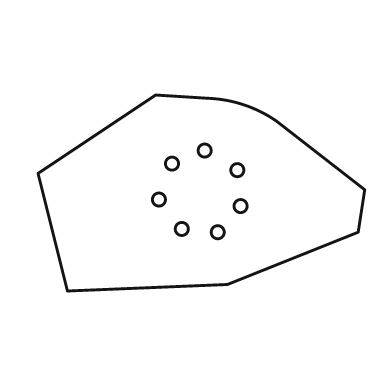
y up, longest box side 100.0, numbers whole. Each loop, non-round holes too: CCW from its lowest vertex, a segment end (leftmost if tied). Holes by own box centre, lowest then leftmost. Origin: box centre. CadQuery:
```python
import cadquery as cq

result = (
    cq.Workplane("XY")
    .moveTo(-41.0, -30.0)
    .lineTo(8.0, -28.0)
    .lineTo(48.0, -12.0)
    .lineTo(50.0, 1.0)
    .lineTo(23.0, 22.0)
    .threePointArc((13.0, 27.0), (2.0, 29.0))
    .lineTo(-14.0, 30.0)
    .lineTo(-50.0, 6.0)
    .close()
    .moveTo(5.0, -12.0)
    .circle(2.0)
    .moveTo(-6.0, -11.0)
    .circle(2.0)
    .moveTo(12.0, -4.0)
    .circle(2.0)
    .moveTo(-13.0, -2.0)
    .circle(2.0)
    .moveTo(11.0, 7.0)
    .circle(2.0)
    .moveTo(-9.0, 9.0)
    .circle(2.0)
    .moveTo(1.0, 13.0)
    .circle(2.0)
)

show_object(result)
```